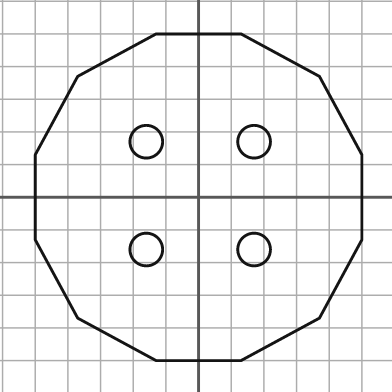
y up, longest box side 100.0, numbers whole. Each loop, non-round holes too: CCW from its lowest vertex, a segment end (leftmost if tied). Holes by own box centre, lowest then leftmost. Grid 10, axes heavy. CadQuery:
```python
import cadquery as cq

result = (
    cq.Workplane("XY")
    .moveTo(-13.0, -50.0)
    .lineTo(13.0, -50.0)
    .lineTo(37.0, -37.0)
    .lineTo(50.0, -13.0)
    .lineTo(50.0, 13.0)
    .lineTo(37.0, 37.0)
    .lineTo(13.0, 50.0)
    .lineTo(-13.0, 50.0)
    .lineTo(-37.0, 37.0)
    .lineTo(-50.0, 13.0)
    .lineTo(-50.0, -13.0)
    .lineTo(-37.0, -37.0)
    .close()
    .moveTo(-16.0, -16.0)
    .circle(5.0)
    .moveTo(17.0, -16.0)
    .circle(5.0)
    .moveTo(-16.0, 17.0)
    .circle(5.0)
    .moveTo(17.0, 17.0)
    .circle(5.0)
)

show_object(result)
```